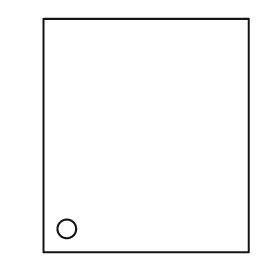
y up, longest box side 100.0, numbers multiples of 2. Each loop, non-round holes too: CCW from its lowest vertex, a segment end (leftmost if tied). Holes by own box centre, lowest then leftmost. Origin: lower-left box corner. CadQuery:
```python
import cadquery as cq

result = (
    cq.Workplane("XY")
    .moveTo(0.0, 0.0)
    .lineTo(88.0, 0.0)
    .lineTo(88.0, 100.0)
    .lineTo(0.0, 100.0)
    .close()
    .moveTo(10.0, 10.0)
    .circle(4.0)
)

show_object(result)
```